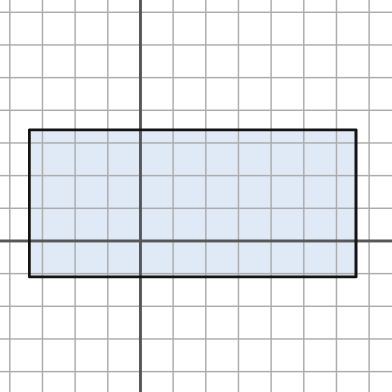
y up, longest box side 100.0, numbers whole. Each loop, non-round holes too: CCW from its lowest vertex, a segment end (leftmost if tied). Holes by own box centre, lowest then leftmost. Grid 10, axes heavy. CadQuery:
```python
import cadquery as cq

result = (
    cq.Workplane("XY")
    .moveTo(-34.0, -11.0)
    .lineTo(66.0, -11.0)
    .lineTo(66.0, 34.0)
    .lineTo(-34.0, 34.0)
    .close()
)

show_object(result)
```